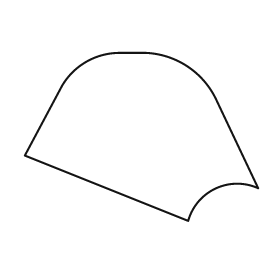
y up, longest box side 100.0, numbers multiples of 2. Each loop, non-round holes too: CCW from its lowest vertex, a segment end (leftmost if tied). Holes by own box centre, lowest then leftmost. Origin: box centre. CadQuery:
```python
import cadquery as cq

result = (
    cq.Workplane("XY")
    .moveTo(20.0, -36.0)
    .threePointArc((32.0, -22.0), (50.0, -22.0))
    .lineTo(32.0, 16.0)
    .threePointArc((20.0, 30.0), (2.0, 36.0))
    .lineTo(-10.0, 36.0)
    .threePointArc((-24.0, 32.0), (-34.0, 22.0))
    .lineTo(-50.0, -8.0)
    .close()
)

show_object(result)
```